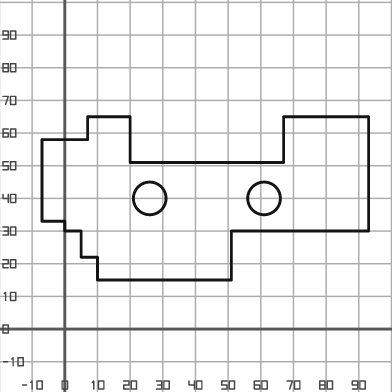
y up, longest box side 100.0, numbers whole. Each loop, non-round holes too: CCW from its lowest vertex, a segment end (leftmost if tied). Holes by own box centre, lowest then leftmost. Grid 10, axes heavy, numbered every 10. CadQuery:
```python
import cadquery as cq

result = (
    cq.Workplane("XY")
    .moveTo(10.0, 15.0)
    .lineTo(51.0, 15.0)
    .lineTo(51.0, 30.0)
    .lineTo(93.0, 30.0)
    .lineTo(93.0, 65.0)
    .lineTo(67.0, 65.0)
    .lineTo(67.0, 51.0)
    .lineTo(20.0, 51.0)
    .lineTo(20.0, 65.0)
    .lineTo(7.0, 65.0)
    .lineTo(7.0, 58.0)
    .lineTo(-7.0, 58.0)
    .lineTo(-7.0, 33.0)
    .lineTo(0.0, 33.0)
    .lineTo(0.0, 30.0)
    .lineTo(5.0, 30.0)
    .lineTo(5.0, 22.0)
    .lineTo(10.0, 22.0)
    .close()
    .moveTo(26.0, 40.0)
    .circle(5.0)
    .moveTo(61.0, 40.0)
    .circle(5.0)
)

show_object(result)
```